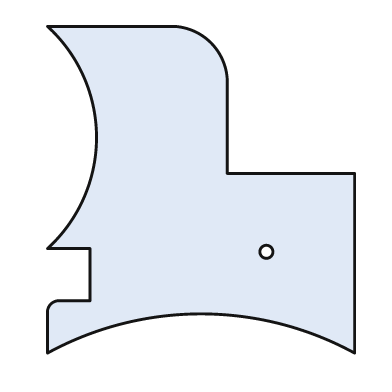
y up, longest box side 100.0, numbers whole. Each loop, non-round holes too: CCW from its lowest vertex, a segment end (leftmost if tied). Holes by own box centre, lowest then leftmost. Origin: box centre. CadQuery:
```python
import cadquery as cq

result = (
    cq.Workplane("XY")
    .moveTo(-47.0, -50.0)
    .threePointArc((0.0, -38.0), (47.0, -50.0))
    .lineTo(47.0, 5.0)
    .lineTo(8.0, 5.0)
    .lineTo(8.0, 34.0)
    .threePointArc((3.0, 45.0), (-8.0, 50.0))
    .lineTo(-47.0, 50.0)
    .threePointArc((-32.0, 16.0), (-47.0, -18.0))
    .lineTo(-34.0, -18.0)
    .lineTo(-34.0, -34.0)
    .lineTo(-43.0, -34.0)
    .threePointArc((-46.0, -35.0), (-47.0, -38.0))
    .close()
    .moveTo(20.0, -19.0)
    .circle(2.0)
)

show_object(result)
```